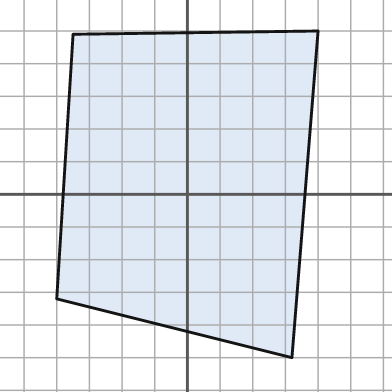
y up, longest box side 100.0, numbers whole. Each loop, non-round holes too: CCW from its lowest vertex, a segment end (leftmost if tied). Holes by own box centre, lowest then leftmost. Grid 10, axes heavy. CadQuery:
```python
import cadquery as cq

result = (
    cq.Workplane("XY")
    .moveTo(32.0, -50.0)
    .lineTo(40.0, 50.0)
    .lineTo(-35.0, 49.0)
    .lineTo(-40.0, -32.0)
    .close()
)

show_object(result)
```